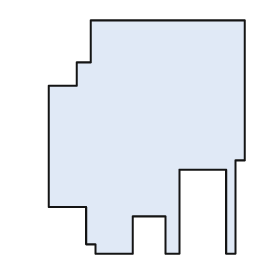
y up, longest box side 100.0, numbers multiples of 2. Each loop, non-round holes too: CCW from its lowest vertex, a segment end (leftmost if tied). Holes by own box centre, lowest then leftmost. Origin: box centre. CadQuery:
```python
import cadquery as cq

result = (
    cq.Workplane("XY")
    .moveTo(-22.0, -50.0)
    .lineTo(-6.0, -50.0)
    .lineTo(-6.0, -34.0)
    .lineTo(8.0, -34.0)
    .lineTo(8.0, -50.0)
    .lineTo(14.0, -50.0)
    .lineTo(14.0, -14.0)
    .lineTo(34.0, -14.0)
    .lineTo(34.0, -50.0)
    .lineTo(38.0, -50.0)
    .lineTo(38.0, -10.0)
    .lineTo(42.0, -10.0)
    .lineTo(42.0, 50.0)
    .lineTo(-24.0, 50.0)
    .lineTo(-24.0, 32.0)
    .lineTo(-30.0, 32.0)
    .lineTo(-30.0, 22.0)
    .lineTo(-42.0, 22.0)
    .lineTo(-42.0, -30.0)
    .lineTo(-26.0, -30.0)
    .lineTo(-26.0, -46.0)
    .lineTo(-22.0, -46.0)
    .close()
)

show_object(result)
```